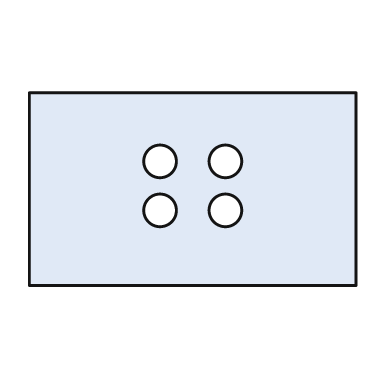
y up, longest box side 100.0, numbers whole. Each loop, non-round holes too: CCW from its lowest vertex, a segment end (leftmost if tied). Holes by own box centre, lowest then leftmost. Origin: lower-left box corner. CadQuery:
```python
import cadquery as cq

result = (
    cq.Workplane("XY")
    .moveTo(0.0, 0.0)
    .lineTo(100.0, 0.0)
    .lineTo(100.0, 59.0)
    .lineTo(0.0, 59.0)
    .close()
    .moveTo(40.0, 23.0)
    .circle(5.0)
    .moveTo(60.0, 23.0)
    .circle(5.0)
    .moveTo(40.0, 38.0)
    .circle(5.0)
    .moveTo(60.0, 38.0)
    .circle(5.0)
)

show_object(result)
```